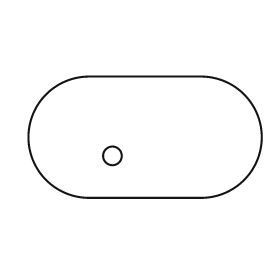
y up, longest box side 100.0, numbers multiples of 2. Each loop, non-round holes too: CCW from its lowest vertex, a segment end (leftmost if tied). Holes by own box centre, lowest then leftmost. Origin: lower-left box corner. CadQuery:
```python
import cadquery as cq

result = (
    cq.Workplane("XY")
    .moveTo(26.0, 0.0)
    .lineTo(74.0, 0.0)
    .threePointArc((100.0, 26.0), (74.0, 52.0))
    .lineTo(26.0, 52.0)
    .threePointArc((0.0, 26.0), (26.0, 0.0))
    .close()
    .moveTo(36.0, 18.0)
    .circle(4.0)
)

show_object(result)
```